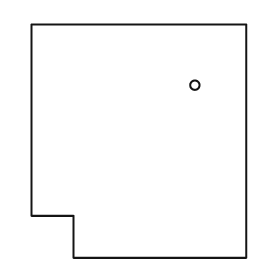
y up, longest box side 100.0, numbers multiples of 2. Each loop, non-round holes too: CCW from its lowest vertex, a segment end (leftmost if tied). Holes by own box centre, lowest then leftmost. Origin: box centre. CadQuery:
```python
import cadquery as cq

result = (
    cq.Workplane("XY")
    .moveTo(-28.0, -50.0)
    .lineTo(46.0, -50.0)
    .lineTo(46.0, 50.0)
    .lineTo(-46.0, 50.0)
    .lineTo(-46.0, -32.0)
    .lineTo(-28.0, -32.0)
    .close()
    .moveTo(24.0, 24.0)
    .circle(2.0)
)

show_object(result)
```